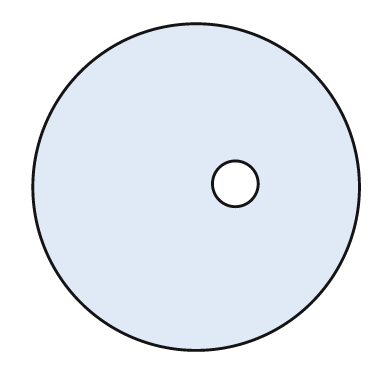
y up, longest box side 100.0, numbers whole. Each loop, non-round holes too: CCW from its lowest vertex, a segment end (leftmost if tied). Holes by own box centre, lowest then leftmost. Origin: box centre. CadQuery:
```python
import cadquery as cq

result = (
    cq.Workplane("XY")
    .moveTo(0.0, 0.0)
    .circle(50.0)
    .moveTo(12.0, 1.0)
    .circle(7.0)
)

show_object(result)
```